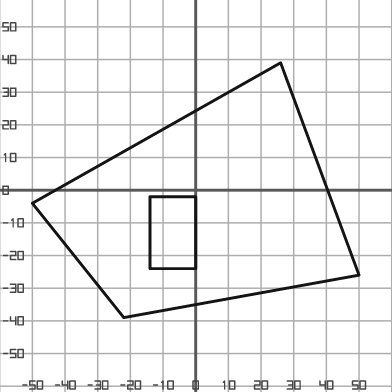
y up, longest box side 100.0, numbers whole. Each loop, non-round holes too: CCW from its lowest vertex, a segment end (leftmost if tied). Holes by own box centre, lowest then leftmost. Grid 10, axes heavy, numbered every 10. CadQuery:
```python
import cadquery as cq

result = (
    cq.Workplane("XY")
    .moveTo(-22.0, -39.0)
    .lineTo(50.0, -26.0)
    .lineTo(26.0, 39.0)
    .lineTo(-50.0, -4.0)
    .close()
    .moveTo(-14.0, -24.0)
    .lineTo(0.0, -24.0)
    .lineTo(0.0, -2.0)
    .lineTo(-14.0, -2.0)
    .close()
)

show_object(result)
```